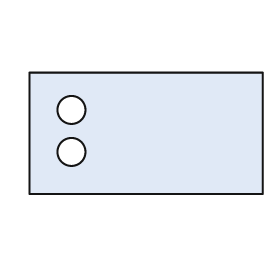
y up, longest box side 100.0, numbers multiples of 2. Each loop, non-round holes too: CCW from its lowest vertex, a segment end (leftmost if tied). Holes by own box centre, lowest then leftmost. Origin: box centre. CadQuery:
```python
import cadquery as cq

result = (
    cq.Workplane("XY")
    .moveTo(-50.0, -26.0)
    .lineTo(50.0, -26.0)
    .lineTo(50.0, 26.0)
    .lineTo(-50.0, 26.0)
    .close()
    .moveTo(-32.0, -8.0)
    .circle(6.0)
    .moveTo(-32.0, 10.0)
    .circle(6.0)
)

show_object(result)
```